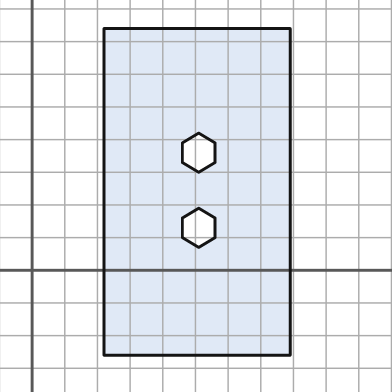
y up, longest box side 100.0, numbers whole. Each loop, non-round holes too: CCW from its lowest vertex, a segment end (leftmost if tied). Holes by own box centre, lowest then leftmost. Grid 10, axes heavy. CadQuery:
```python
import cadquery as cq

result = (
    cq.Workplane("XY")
    .moveTo(22.0, -26.0)
    .lineTo(79.0, -26.0)
    .lineTo(79.0, 74.0)
    .lineTo(22.0, 74.0)
    .close()
    .moveTo(51.0, 7.0)
    .lineTo(56.0, 10.0)
    .lineTo(56.0, 16.0)
    .lineTo(51.0, 19.0)
    .lineTo(46.0, 16.0)
    .lineTo(46.0, 10.0)
    .close()
    .moveTo(51.0, 30.0)
    .lineTo(56.0, 33.0)
    .lineTo(56.0, 39.0)
    .lineTo(51.0, 42.0)
    .lineTo(46.0, 39.0)
    .lineTo(46.0, 33.0)
    .close()
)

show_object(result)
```